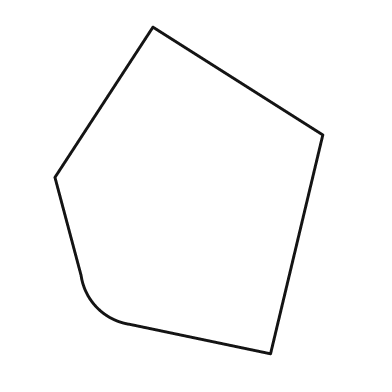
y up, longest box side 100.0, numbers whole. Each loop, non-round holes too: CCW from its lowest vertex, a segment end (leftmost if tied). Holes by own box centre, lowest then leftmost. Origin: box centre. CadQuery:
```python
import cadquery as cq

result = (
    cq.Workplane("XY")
    .moveTo(25.0, -50.0)
    .lineTo(41.0, 17.0)
    .lineTo(-11.0, 50.0)
    .lineTo(-41.0, 4.0)
    .lineTo(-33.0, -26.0)
    .threePointArc((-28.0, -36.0), (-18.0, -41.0))
    .close()
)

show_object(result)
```